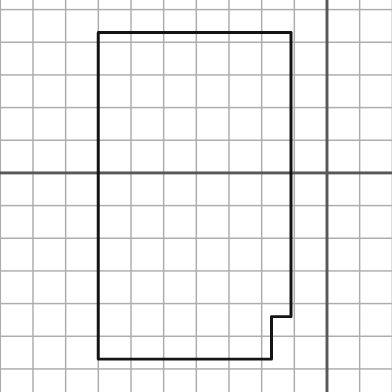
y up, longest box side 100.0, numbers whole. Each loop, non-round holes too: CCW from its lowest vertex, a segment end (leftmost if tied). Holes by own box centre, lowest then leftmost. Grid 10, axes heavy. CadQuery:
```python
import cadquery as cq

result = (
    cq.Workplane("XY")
    .moveTo(-70.0, -57.0)
    .lineTo(-17.0, -57.0)
    .lineTo(-17.0, -44.0)
    .lineTo(-11.0, -44.0)
    .lineTo(-11.0, 43.0)
    .lineTo(-70.0, 43.0)
    .close()
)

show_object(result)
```